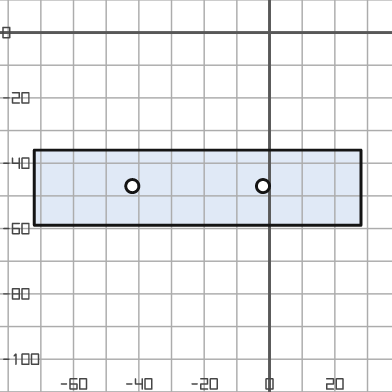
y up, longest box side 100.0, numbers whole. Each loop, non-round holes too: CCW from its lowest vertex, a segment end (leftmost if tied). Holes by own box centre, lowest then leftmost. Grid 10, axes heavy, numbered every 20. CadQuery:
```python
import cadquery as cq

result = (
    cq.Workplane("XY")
    .moveTo(-72.0, -59.0)
    .lineTo(28.0, -59.0)
    .lineTo(28.0, -36.0)
    .lineTo(-72.0, -36.0)
    .close()
    .moveTo(-42.0, -47.0)
    .circle(2.0)
    .moveTo(-2.0, -47.0)
    .circle(2.0)
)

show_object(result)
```